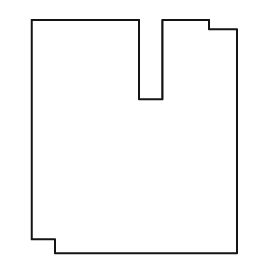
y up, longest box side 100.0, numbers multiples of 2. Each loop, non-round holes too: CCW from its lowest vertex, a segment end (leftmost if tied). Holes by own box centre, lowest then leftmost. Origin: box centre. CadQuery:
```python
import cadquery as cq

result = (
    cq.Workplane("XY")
    .moveTo(-34.0, -50.0)
    .lineTo(44.0, -50.0)
    .lineTo(44.0, 46.0)
    .lineTo(32.0, 46.0)
    .lineTo(32.0, 50.0)
    .lineTo(12.0, 50.0)
    .lineTo(12.0, 16.0)
    .lineTo(2.0, 16.0)
    .lineTo(2.0, 50.0)
    .lineTo(-44.0, 50.0)
    .lineTo(-44.0, -44.0)
    .lineTo(-34.0, -44.0)
    .close()
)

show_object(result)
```